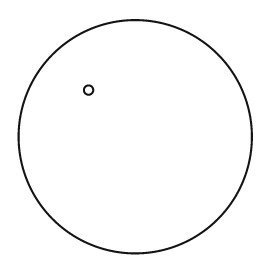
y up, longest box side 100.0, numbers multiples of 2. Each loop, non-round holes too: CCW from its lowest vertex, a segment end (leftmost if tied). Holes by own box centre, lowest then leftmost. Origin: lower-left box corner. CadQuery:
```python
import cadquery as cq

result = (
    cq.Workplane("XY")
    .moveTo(50.0, 50.0)
    .circle(50.0)
    .moveTo(30.0, 70.0)
    .circle(2.0)
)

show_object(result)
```